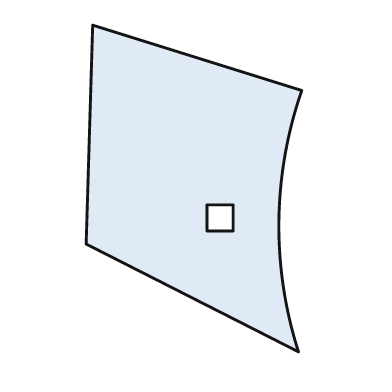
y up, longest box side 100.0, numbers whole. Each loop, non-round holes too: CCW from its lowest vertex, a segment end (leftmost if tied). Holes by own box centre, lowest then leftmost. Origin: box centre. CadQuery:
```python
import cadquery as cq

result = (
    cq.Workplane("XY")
    .moveTo(32.0, -50.0)
    .threePointArc((26.0, -10.0), (33.0, 30.0))
    .lineTo(-31.0, 50.0)
    .lineTo(-33.0, -17.0)
    .close()
    .moveTo(4.0, -13.0)
    .lineTo(12.0, -13.0)
    .lineTo(12.0, -5.0)
    .lineTo(4.0, -5.0)
    .close()
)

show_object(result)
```